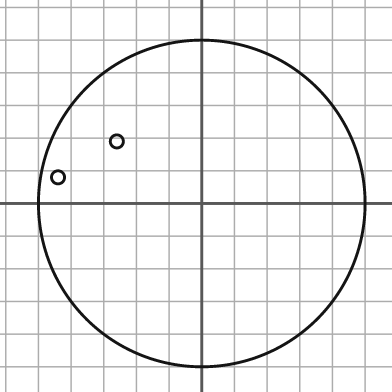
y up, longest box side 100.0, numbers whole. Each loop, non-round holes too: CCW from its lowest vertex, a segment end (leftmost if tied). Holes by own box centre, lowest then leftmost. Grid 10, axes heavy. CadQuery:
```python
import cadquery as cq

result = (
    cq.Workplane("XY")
    .moveTo(0.0, 0.0)
    .circle(50.0)
    .moveTo(-44.0, 8.0)
    .circle(2.0)
    .moveTo(-26.0, 19.0)
    .circle(2.0)
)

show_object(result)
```